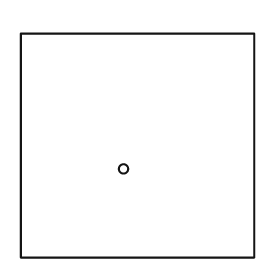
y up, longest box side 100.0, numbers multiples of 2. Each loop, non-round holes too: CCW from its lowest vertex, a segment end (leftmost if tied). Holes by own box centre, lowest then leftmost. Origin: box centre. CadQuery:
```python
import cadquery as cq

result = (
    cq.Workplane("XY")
    .moveTo(-50.0, -48.0)
    .lineTo(50.0, -48.0)
    .lineTo(50.0, 48.0)
    .lineTo(-50.0, 48.0)
    .close()
    .moveTo(-6.0, -10.0)
    .circle(2.0)
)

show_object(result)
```